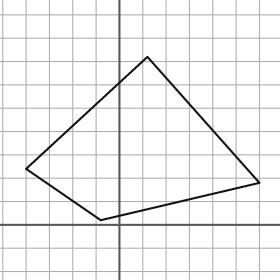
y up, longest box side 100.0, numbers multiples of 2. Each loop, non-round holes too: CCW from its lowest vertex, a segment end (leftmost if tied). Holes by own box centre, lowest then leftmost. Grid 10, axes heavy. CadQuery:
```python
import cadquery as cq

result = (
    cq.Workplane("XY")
    .moveTo(-8.0, 2.0)
    .lineTo(60.0, 18.0)
    .lineTo(12.0, 72.0)
    .lineTo(-40.0, 24.0)
    .close()
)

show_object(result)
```